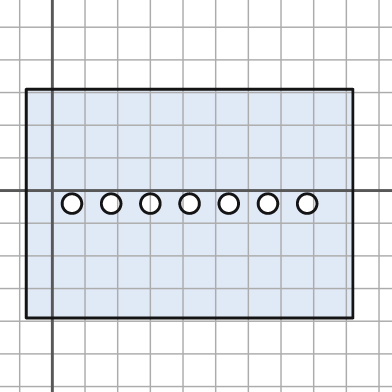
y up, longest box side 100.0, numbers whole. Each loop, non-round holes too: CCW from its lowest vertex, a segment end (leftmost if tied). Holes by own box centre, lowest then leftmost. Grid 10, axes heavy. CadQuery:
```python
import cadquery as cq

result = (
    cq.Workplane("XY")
    .moveTo(-8.0, -39.0)
    .lineTo(92.0, -39.0)
    .lineTo(92.0, 31.0)
    .lineTo(-8.0, 31.0)
    .close()
    .moveTo(6.0, -4.0)
    .circle(3.0)
    .moveTo(18.0, -4.0)
    .circle(3.0)
    .moveTo(30.0, -4.0)
    .circle(3.0)
    .moveTo(42.0, -4.0)
    .circle(3.0)
    .moveTo(54.0, -4.0)
    .circle(3.0)
    .moveTo(66.0, -4.0)
    .circle(3.0)
    .moveTo(78.0, -4.0)
    .circle(3.0)
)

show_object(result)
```